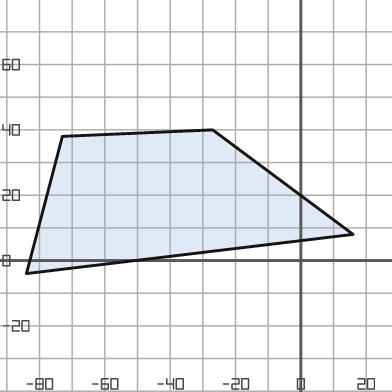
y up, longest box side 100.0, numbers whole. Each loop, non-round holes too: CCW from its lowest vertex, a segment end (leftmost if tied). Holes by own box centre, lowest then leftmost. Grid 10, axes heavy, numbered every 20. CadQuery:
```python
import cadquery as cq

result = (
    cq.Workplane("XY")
    .moveTo(-84.0, -4.0)
    .lineTo(16.0, 8.0)
    .lineTo(-27.0, 40.0)
    .lineTo(-73.0, 38.0)
    .close()
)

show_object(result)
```